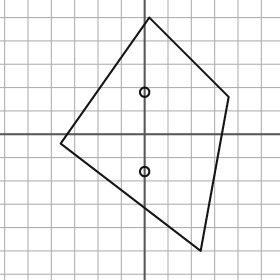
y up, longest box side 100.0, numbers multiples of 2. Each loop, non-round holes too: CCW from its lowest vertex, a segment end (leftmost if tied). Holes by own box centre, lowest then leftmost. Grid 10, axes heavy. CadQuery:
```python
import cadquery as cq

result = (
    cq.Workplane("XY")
    .moveTo(24.0, -50.0)
    .lineTo(36.0, 16.0)
    .lineTo(2.0, 50.0)
    .lineTo(-36.0, -4.0)
    .close()
    .moveTo(0.0, -16.0)
    .circle(2.0)
    .moveTo(0.0, 18.0)
    .circle(2.0)
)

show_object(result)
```